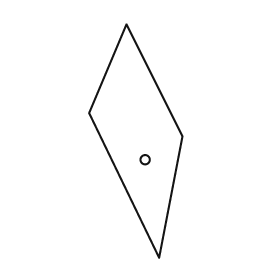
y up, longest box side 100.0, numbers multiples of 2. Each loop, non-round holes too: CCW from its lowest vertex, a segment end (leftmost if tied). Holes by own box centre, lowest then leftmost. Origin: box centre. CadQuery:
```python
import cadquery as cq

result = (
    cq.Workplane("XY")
    .moveTo(10.0, -50.0)
    .lineTo(20.0, 2.0)
    .lineTo(-4.0, 50.0)
    .lineTo(-20.0, 12.0)
    .close()
    .moveTo(4.0, -8.0)
    .circle(2.0)
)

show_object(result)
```